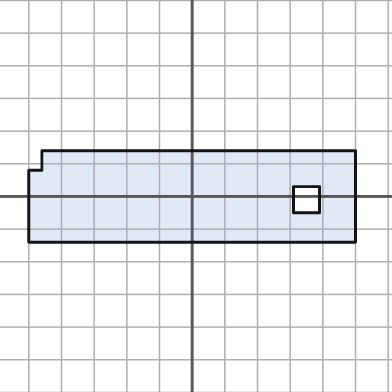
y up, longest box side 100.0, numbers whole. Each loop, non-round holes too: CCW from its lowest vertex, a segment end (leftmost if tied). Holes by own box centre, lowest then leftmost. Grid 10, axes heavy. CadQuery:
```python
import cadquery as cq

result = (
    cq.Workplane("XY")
    .moveTo(-50.0, -14.0)
    .lineTo(50.0, -14.0)
    .lineTo(50.0, 14.0)
    .lineTo(-46.0, 14.0)
    .lineTo(-46.0, 8.0)
    .lineTo(-50.0, 8.0)
    .close()
    .moveTo(31.0, -5.0)
    .lineTo(39.0, -5.0)
    .lineTo(39.0, 3.0)
    .lineTo(31.0, 3.0)
    .close()
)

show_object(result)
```